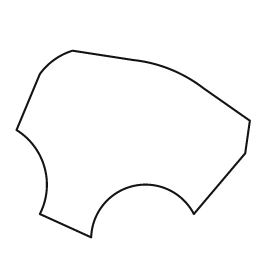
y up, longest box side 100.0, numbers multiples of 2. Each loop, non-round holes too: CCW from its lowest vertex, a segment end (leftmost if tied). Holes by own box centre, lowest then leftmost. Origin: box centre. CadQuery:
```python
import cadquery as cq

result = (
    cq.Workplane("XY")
    .moveTo(-18.0, -40.0)
    .threePointArc((0.0, -18.0), (26.0, -30.0))
    .lineTo(48.0, -4.0)
    .lineTo(50.0, 10.0)
    .lineTo(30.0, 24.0)
    .threePointArc((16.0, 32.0), (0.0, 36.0))
    .lineTo(-26.0, 40.0)
    .threePointArc((-34.0, 36.0), (-40.0, 30.0))
    .lineTo(-50.0, 6.0)
    .threePointArc((-38.0, -10.0), (-40.0, -30.0))
    .close()
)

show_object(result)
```